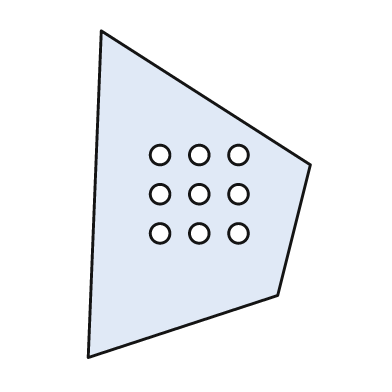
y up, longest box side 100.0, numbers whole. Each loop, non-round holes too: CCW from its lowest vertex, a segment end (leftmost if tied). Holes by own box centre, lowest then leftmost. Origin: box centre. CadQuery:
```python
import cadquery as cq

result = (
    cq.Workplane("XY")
    .moveTo(-34.0, -50.0)
    .lineTo(24.0, -31.0)
    .lineTo(34.0, 9.0)
    .lineTo(-30.0, 50.0)
    .close()
    .moveTo(-12.0, -12.0)
    .circle(3.0)
    .moveTo(0.0, -12.0)
    .circle(3.0)
    .moveTo(12.0, -12.0)
    .circle(3.0)
    .moveTo(-12.0, 0.0)
    .circle(3.0)
    .moveTo(0.0, 0.0)
    .circle(3.0)
    .moveTo(12.0, 0.0)
    .circle(3.0)
    .moveTo(-12.0, 12.0)
    .circle(3.0)
    .moveTo(0.0, 12.0)
    .circle(3.0)
    .moveTo(12.0, 12.0)
    .circle(3.0)
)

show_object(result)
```